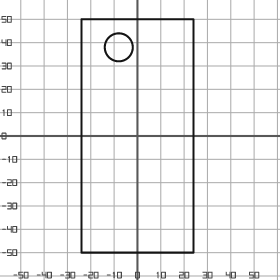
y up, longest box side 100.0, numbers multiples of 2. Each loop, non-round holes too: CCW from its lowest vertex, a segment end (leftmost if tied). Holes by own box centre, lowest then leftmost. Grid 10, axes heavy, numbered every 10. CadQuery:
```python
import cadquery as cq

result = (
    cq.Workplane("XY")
    .moveTo(-24.0, -50.0)
    .lineTo(24.0, -50.0)
    .lineTo(24.0, 50.0)
    .lineTo(-24.0, 50.0)
    .close()
    .moveTo(-8.0, 38.0)
    .circle(6.0)
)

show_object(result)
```